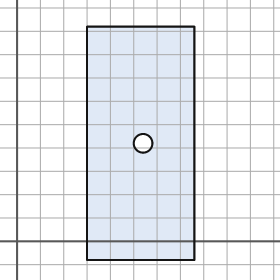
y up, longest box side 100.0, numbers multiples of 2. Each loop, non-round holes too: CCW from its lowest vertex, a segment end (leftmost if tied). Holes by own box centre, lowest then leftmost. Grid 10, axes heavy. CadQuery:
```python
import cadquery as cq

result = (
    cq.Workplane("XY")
    .moveTo(30.0, -8.0)
    .lineTo(76.0, -8.0)
    .lineTo(76.0, 92.0)
    .lineTo(30.0, 92.0)
    .close()
    .moveTo(54.0, 42.0)
    .circle(4.0)
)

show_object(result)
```